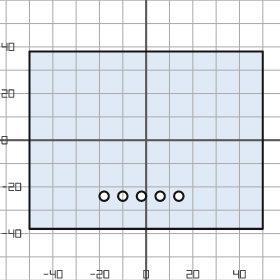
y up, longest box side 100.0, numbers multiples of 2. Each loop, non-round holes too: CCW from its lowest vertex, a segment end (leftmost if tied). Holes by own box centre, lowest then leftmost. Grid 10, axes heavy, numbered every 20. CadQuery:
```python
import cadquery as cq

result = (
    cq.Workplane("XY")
    .moveTo(-50.0, -38.0)
    .lineTo(50.0, -38.0)
    .lineTo(50.0, 38.0)
    .lineTo(-50.0, 38.0)
    .close()
    .moveTo(-18.0, -24.0)
    .circle(2.0)
    .moveTo(-10.0, -24.0)
    .circle(2.0)
    .moveTo(-2.0, -24.0)
    .circle(2.0)
    .moveTo(6.0, -24.0)
    .circle(2.0)
    .moveTo(14.0, -24.0)
    .circle(2.0)
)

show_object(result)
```